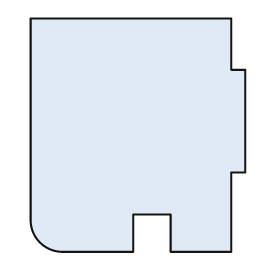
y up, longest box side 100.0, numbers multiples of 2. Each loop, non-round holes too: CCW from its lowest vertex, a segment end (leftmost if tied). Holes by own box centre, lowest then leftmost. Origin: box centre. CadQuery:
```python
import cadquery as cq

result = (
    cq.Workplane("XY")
    .moveTo(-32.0, -50.0)
    .lineTo(-2.0, -50.0)
    .lineTo(-2.0, -34.0)
    .lineTo(14.0, -34.0)
    .lineTo(14.0, -50.0)
    .lineTo(40.0, -50.0)
    .lineTo(40.0, -16.0)
    .lineTo(46.0, -16.0)
    .lineTo(46.0, 28.0)
    .lineTo(40.0, 28.0)
    .lineTo(40.0, 50.0)
    .lineTo(-46.0, 50.0)
    .lineTo(-46.0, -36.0)
    .threePointArc((-42.0, -46.0), (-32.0, -50.0))
    .close()
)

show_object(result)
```